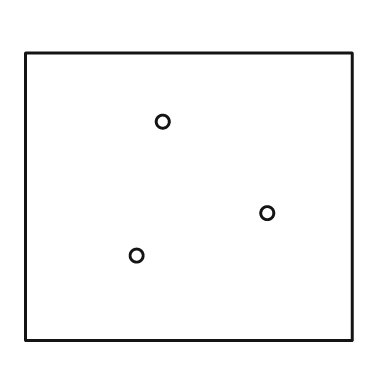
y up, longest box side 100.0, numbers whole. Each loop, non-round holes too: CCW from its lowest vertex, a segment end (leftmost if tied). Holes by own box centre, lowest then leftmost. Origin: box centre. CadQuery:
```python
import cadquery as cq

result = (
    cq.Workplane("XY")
    .moveTo(-50.0, -44.0)
    .lineTo(50.0, -44.0)
    .lineTo(50.0, 44.0)
    .lineTo(-50.0, 44.0)
    .close()
    .moveTo(-16.0, -18.0)
    .circle(2.0)
    .moveTo(24.0, -5.0)
    .circle(2.0)
    .moveTo(-8.0, 23.0)
    .circle(2.0)
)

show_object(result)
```